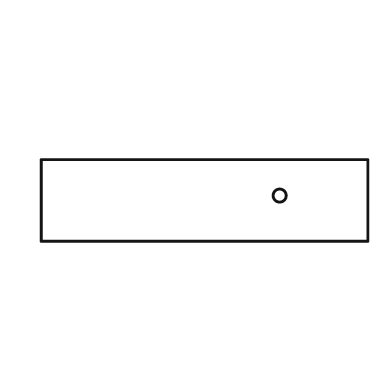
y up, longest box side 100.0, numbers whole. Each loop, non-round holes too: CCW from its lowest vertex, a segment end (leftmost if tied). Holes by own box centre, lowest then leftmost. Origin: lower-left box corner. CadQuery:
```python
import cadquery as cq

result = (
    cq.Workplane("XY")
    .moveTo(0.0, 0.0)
    .lineTo(100.0, 0.0)
    .lineTo(100.0, 25.0)
    .lineTo(0.0, 25.0)
    .close()
    .moveTo(73.0, 14.0)
    .circle(2.0)
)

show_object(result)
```